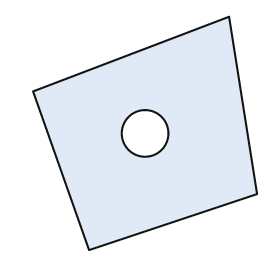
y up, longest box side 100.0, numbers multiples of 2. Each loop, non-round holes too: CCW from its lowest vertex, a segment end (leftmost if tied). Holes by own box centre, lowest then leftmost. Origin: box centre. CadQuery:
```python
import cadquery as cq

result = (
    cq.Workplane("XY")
    .moveTo(-24.0, -50.0)
    .lineTo(48.0, -26.0)
    .lineTo(36.0, 50.0)
    .lineTo(-48.0, 18.0)
    .close()
    .moveTo(0.0, 0.0)
    .circle(10.0)
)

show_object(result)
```